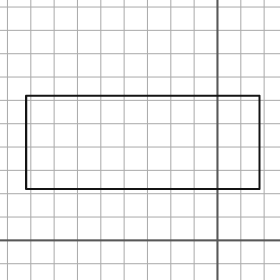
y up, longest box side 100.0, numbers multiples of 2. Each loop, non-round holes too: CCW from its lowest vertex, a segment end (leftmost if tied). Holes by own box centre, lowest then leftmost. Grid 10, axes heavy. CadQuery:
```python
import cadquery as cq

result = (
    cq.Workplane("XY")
    .moveTo(-82.0, 22.0)
    .lineTo(18.0, 22.0)
    .lineTo(18.0, 62.0)
    .lineTo(-82.0, 62.0)
    .close()
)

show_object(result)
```